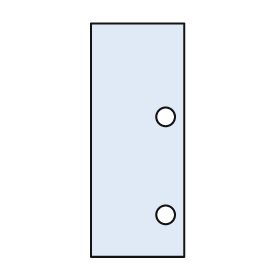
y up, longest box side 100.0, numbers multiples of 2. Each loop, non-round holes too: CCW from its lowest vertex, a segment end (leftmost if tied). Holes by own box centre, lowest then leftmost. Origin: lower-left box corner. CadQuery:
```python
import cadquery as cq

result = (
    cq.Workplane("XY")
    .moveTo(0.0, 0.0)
    .lineTo(40.0, 0.0)
    .lineTo(40.0, 100.0)
    .lineTo(0.0, 100.0)
    .close()
    .moveTo(32.0, 18.0)
    .circle(4.0)
    .moveTo(32.0, 60.0)
    .circle(4.0)
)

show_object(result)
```